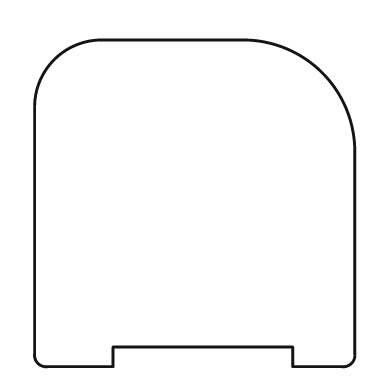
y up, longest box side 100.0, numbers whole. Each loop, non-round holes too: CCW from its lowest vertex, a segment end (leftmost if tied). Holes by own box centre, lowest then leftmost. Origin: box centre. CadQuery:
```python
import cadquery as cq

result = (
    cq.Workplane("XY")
    .moveTo(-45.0, -50.0)
    .lineTo(-25.0, -50.0)
    .lineTo(-25.0, -44.0)
    .lineTo(30.0, -44.0)
    .lineTo(30.0, -50.0)
    .lineTo(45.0, -50.0)
    .threePointArc((48.0, -49.0), (49.0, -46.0))
    .lineTo(49.0, 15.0)
    .threePointArc((39.0, 40.0), (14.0, 50.0))
    .lineTo(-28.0, 50.0)
    .threePointArc((-43.0, 44.0), (-49.0, 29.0))
    .lineTo(-49.0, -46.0)
    .threePointArc((-48.0, -49.0), (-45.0, -50.0))
    .close()
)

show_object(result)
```